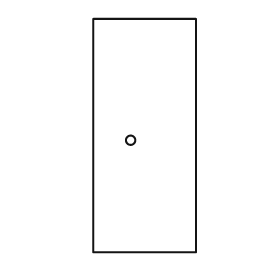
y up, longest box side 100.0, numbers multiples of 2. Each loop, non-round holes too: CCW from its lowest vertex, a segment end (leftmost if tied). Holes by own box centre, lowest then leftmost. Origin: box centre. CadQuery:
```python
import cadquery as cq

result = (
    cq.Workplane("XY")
    .moveTo(-22.0, -50.0)
    .lineTo(22.0, -50.0)
    .lineTo(22.0, 50.0)
    .lineTo(-22.0, 50.0)
    .close()
    .moveTo(-6.0, -2.0)
    .circle(2.0)
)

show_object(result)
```